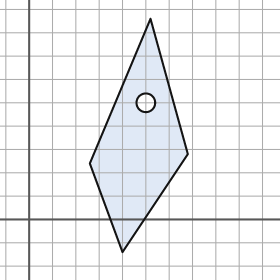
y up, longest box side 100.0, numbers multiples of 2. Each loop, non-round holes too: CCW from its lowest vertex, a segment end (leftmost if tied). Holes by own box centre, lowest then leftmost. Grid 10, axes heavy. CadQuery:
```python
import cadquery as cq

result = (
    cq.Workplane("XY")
    .moveTo(40.0, -14.0)
    .lineTo(68.0, 28.0)
    .lineTo(52.0, 86.0)
    .lineTo(26.0, 24.0)
    .close()
    .moveTo(50.0, 50.0)
    .circle(4.0)
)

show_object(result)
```